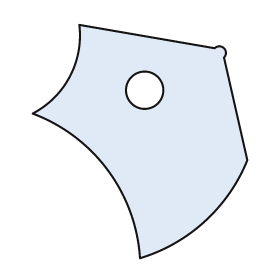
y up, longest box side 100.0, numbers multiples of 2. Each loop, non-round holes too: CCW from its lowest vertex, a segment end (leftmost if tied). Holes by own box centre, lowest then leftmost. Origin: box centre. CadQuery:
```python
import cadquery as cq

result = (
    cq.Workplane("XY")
    .moveTo(0.0, -50.0)
    .threePointArc((28.0, -34.0), (46.0, -8.0))
    .lineTo(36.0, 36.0)
    .threePointArc((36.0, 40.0), (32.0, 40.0))
    .lineTo(-26.0, 50.0)
    .threePointArc((-30.0, 28.0), (-46.0, 12.0))
    .threePointArc((-14.0, -12.0), (0.0, -50.0))
    .close()
    .moveTo(2.0, 22.0)
    .circle(8.0)
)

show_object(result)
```